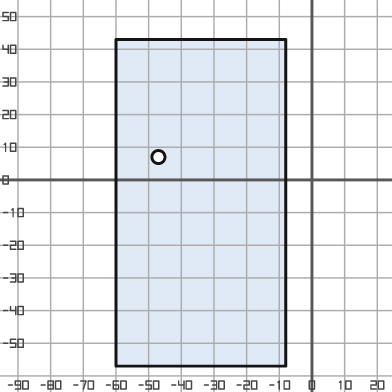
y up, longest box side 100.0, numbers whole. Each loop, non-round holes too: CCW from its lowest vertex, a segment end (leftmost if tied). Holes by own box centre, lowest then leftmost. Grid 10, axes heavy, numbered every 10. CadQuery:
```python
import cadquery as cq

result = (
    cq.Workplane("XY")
    .moveTo(-60.0, -57.0)
    .lineTo(-8.0, -57.0)
    .lineTo(-8.0, 43.0)
    .lineTo(-60.0, 43.0)
    .close()
    .moveTo(-47.0, 7.0)
    .circle(2.0)
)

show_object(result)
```